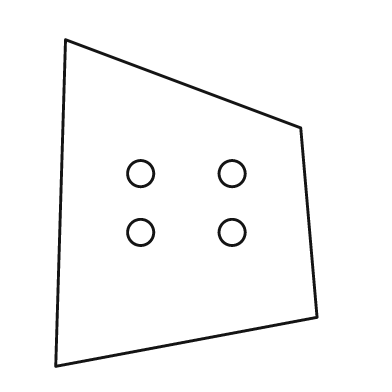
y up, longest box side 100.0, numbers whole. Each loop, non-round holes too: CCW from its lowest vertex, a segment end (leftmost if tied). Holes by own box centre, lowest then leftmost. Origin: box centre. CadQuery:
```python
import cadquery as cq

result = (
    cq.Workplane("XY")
    .moveTo(-40.0, -50.0)
    .lineTo(40.0, -35.0)
    .lineTo(35.0, 23.0)
    .lineTo(-37.0, 50.0)
    .close()
    .moveTo(-14.0, -9.0)
    .circle(4.0)
    .moveTo(14.0, -9.0)
    .circle(4.0)
    .moveTo(-14.0, 9.0)
    .circle(4.0)
    .moveTo(14.0, 9.0)
    .circle(4.0)
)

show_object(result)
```